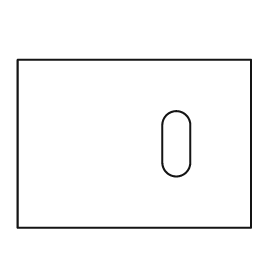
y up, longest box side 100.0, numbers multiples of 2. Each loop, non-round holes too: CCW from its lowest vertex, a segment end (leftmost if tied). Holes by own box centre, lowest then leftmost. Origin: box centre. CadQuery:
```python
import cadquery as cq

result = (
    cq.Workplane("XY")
    .moveTo(-50.0, -36.0)
    .lineTo(50.0, -36.0)
    .lineTo(50.0, 36.0)
    .lineTo(-50.0, 36.0)
    .close()
    .moveTo(12.0, -8.0)
    .threePointArc((18.0, -14.0), (24.0, -8.0))
    .lineTo(24.0, 8.0)
    .threePointArc((18.0, 14.0), (12.0, 8.0))
    .close()
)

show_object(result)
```